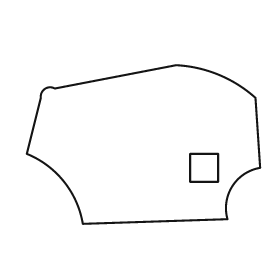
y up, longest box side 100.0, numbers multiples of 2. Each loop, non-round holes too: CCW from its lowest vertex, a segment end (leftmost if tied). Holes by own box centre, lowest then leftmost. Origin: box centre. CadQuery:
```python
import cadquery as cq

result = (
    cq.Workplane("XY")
    .moveTo(-26.0, -34.0)
    .lineTo(36.0, -32.0)
    .threePointArc((38.0, -18.0), (50.0, -10.0))
    .lineTo(48.0, 20.0)
    .threePointArc((32.0, 30.0), (14.0, 34.0))
    .lineTo(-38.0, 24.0)
    .threePointArc((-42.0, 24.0), (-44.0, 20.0))
    .lineTo(-50.0, -4.0)
    .threePointArc((-34.0, -16.0), (-26.0, -34.0))
    .close()
    .moveTo(20.0, -16.0)
    .lineTo(32.0, -16.0)
    .lineTo(32.0, -4.0)
    .lineTo(20.0, -4.0)
    .close()
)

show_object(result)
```